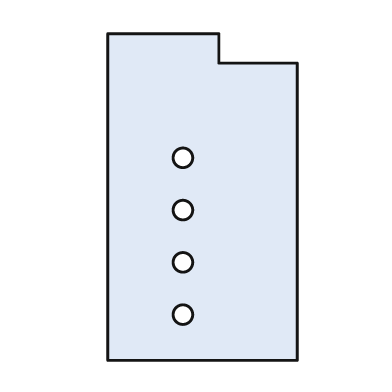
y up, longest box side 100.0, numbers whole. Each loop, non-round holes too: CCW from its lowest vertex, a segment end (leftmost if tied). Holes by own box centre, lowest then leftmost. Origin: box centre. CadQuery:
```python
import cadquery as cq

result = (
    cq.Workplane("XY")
    .moveTo(-29.0, -50.0)
    .lineTo(29.0, -50.0)
    .lineTo(29.0, 41.0)
    .lineTo(5.0, 41.0)
    .lineTo(5.0, 50.0)
    .lineTo(-29.0, 50.0)
    .close()
    .moveTo(-6.0, -36.0)
    .circle(3.0)
    .moveTo(-6.0, -20.0)
    .circle(3.0)
    .moveTo(-6.0, -4.0)
    .circle(3.0)
    .moveTo(-6.0, 12.0)
    .circle(3.0)
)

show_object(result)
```